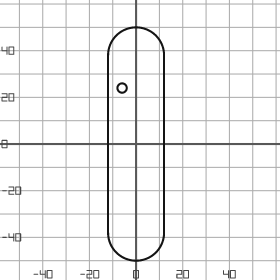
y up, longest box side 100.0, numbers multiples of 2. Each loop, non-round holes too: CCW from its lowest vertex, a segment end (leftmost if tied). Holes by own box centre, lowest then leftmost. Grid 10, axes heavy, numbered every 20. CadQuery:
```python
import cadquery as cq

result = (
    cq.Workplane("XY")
    .moveTo(-12.0, -38.0)
    .threePointArc((0.0, -50.0), (12.0, -38.0))
    .lineTo(12.0, 38.0)
    .threePointArc((0.0, 50.0), (-12.0, 38.0))
    .close()
    .moveTo(-6.0, 24.0)
    .circle(2.0)
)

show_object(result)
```